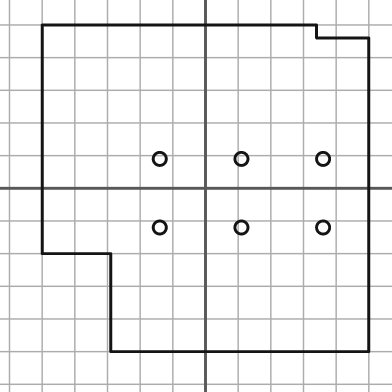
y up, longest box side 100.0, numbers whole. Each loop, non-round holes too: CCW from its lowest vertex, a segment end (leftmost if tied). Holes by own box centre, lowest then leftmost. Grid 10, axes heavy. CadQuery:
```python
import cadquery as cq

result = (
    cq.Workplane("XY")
    .moveTo(-29.0, -50.0)
    .lineTo(50.0, -50.0)
    .lineTo(50.0, 46.0)
    .lineTo(34.0, 46.0)
    .lineTo(34.0, 50.0)
    .lineTo(-50.0, 50.0)
    .lineTo(-50.0, -20.0)
    .lineTo(-29.0, -20.0)
    .close()
    .moveTo(-14.0, -12.0)
    .circle(2.0)
    .moveTo(11.0, -12.0)
    .circle(2.0)
    .moveTo(36.0, -12.0)
    .circle(2.0)
    .moveTo(-14.0, 9.0)
    .circle(2.0)
    .moveTo(11.0, 9.0)
    .circle(2.0)
    .moveTo(36.0, 9.0)
    .circle(2.0)
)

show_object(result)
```